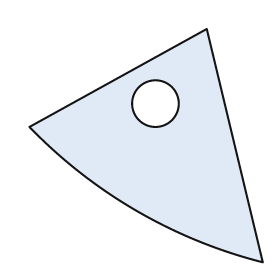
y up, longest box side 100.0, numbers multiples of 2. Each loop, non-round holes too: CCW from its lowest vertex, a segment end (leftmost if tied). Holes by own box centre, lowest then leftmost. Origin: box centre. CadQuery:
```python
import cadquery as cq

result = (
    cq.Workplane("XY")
    .moveTo(50.0, -50.0)
    .lineTo(26.0, 50.0)
    .lineTo(-50.0, 8.0)
    .threePointArc((-4.0, -28.0), (50.0, -50.0))
    .close()
    .moveTo(4.0, 18.0)
    .circle(10.0)
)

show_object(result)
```